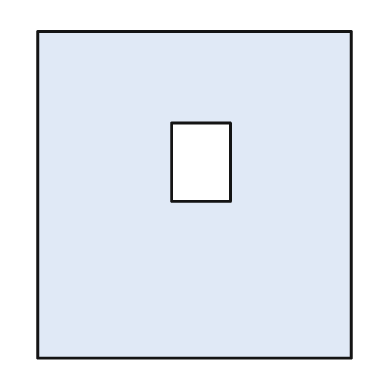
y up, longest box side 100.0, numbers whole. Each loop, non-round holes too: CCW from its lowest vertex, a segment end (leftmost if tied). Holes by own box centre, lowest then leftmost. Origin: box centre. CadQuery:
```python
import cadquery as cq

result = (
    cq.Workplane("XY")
    .moveTo(-48.0, -50.0)
    .lineTo(48.0, -50.0)
    .lineTo(48.0, 50.0)
    .lineTo(-48.0, 50.0)
    .close()
    .moveTo(-7.0, -2.0)
    .lineTo(11.0, -2.0)
    .lineTo(11.0, 22.0)
    .lineTo(-7.0, 22.0)
    .close()
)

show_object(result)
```